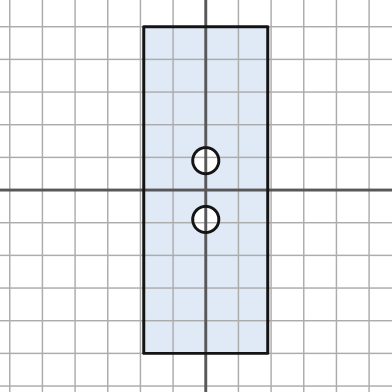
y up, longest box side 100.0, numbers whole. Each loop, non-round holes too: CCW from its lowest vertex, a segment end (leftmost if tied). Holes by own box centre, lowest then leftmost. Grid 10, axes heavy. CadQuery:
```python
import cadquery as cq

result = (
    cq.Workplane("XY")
    .moveTo(-19.0, -50.0)
    .lineTo(19.0, -50.0)
    .lineTo(19.0, 50.0)
    .lineTo(-19.0, 50.0)
    .close()
    .moveTo(0.0, -9.0)
    .circle(4.0)
    .moveTo(0.0, 9.0)
    .circle(4.0)
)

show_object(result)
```